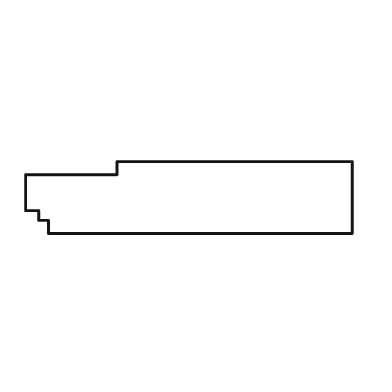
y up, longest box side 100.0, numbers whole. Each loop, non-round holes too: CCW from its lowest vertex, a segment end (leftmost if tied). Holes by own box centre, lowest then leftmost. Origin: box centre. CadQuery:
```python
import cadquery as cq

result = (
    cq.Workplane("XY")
    .moveTo(-43.0, -11.0)
    .lineTo(50.0, -11.0)
    .lineTo(50.0, 11.0)
    .lineTo(-22.0, 11.0)
    .lineTo(-22.0, 7.0)
    .lineTo(-50.0, 7.0)
    .lineTo(-50.0, -4.0)
    .lineTo(-46.0, -4.0)
    .lineTo(-46.0, -7.0)
    .lineTo(-43.0, -7.0)
    .close()
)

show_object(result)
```